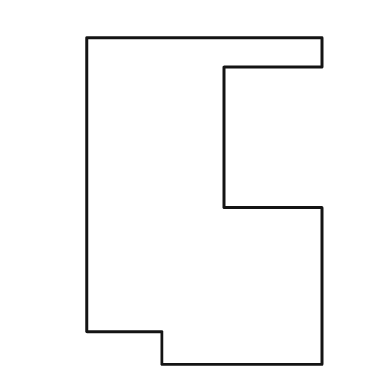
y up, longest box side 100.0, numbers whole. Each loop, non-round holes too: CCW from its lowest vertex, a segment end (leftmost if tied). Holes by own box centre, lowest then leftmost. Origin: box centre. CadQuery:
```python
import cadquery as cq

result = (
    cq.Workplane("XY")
    .moveTo(-13.0, -50.0)
    .lineTo(36.0, -50.0)
    .lineTo(36.0, -2.0)
    .lineTo(6.0, -2.0)
    .lineTo(6.0, 41.0)
    .lineTo(36.0, 41.0)
    .lineTo(36.0, 50.0)
    .lineTo(-36.0, 50.0)
    .lineTo(-36.0, -40.0)
    .lineTo(-13.0, -40.0)
    .close()
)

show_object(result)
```